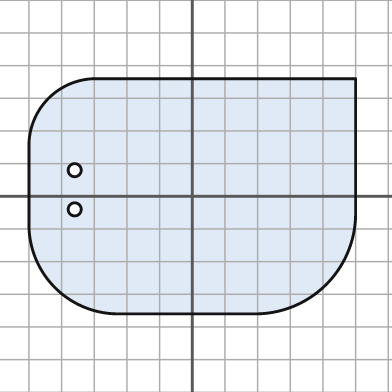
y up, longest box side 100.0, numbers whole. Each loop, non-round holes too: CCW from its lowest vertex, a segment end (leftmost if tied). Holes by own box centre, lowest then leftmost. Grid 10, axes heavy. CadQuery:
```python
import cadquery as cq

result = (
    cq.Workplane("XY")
    .moveTo(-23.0, -36.0)
    .lineTo(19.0, -36.0)
    .threePointArc((41.0, -27.0), (50.0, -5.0))
    .lineTo(50.0, 36.0)
    .lineTo(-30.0, 36.0)
    .threePointArc((-44.0, 30.0), (-50.0, 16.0))
    .lineTo(-50.0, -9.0)
    .threePointArc((-42.0, -28.0), (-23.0, -36.0))
    .close()
    .moveTo(-36.0, -4.0)
    .circle(2.0)
    .moveTo(-36.0, 8.0)
    .circle(2.0)
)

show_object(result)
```